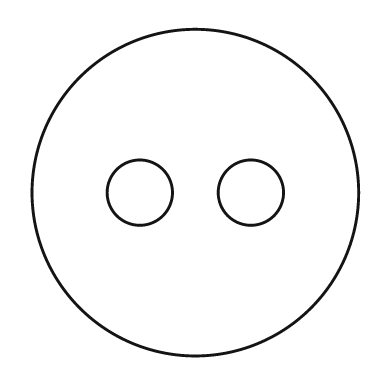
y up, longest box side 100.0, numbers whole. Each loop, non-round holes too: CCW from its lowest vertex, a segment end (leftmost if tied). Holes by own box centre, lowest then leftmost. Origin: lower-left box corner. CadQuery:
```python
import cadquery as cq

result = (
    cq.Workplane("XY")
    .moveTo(50.0, 50.0)
    .circle(50.0)
    .moveTo(33.0, 50.0)
    .circle(10.0)
    .moveTo(67.0, 50.0)
    .circle(10.0)
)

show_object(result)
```